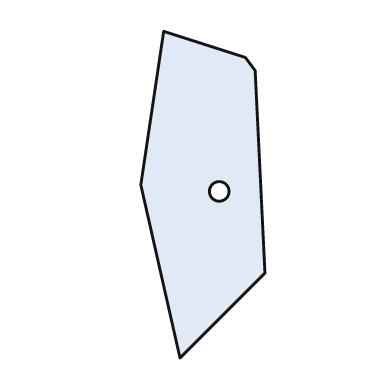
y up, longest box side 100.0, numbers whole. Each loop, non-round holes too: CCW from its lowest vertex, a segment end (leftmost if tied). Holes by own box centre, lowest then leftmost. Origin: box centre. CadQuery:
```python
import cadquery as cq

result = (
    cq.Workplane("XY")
    .moveTo(-7.0, -50.0)
    .lineTo(19.0, -24.0)
    .lineTo(16.0, 38.0)
    .lineTo(13.0, 42.0)
    .lineTo(-12.0, 50.0)
    .lineTo(-19.0, 3.0)
    .close()
    .moveTo(5.0, 1.0)
    .circle(3.0)
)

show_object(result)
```